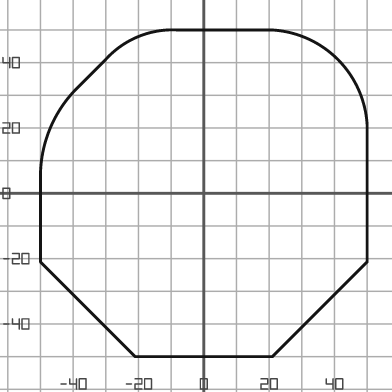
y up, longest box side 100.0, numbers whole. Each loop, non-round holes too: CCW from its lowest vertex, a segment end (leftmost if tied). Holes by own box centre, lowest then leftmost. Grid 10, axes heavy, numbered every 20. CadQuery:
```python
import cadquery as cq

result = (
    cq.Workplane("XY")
    .moveTo(-21.0, -50.0)
    .lineTo(21.0, -50.0)
    .lineTo(50.0, -21.0)
    .lineTo(50.0, 21.0)
    .threePointArc((41.0, 41.0), (21.0, 50.0))
    .lineTo(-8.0, 50.0)
    .threePointArc((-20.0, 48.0), (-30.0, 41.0))
    .lineTo(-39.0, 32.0)
    .threePointArc((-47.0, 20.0), (-50.0, 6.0))
    .lineTo(-50.0, -21.0)
    .close()
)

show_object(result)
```